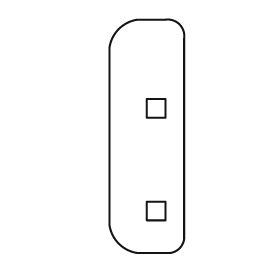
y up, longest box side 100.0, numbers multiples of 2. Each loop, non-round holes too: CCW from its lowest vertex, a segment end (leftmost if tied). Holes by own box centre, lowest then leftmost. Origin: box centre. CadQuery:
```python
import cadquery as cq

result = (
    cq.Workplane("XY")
    .moveTo(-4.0, -50.0)
    .lineTo(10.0, -50.0)
    .threePointArc((14.0, -48.0), (16.0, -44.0))
    .lineTo(16.0, 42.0)
    .threePointArc((14.0, 48.0), (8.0, 50.0))
    .lineTo(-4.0, 50.0)
    .threePointArc((-12.0, 46.0), (-16.0, 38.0))
    .lineTo(-16.0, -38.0)
    .threePointArc((-12.0, -46.0), (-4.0, -50.0))
    .close()
    .moveTo(0.0, -36.0)
    .lineTo(8.0, -36.0)
    .lineTo(8.0, -28.0)
    .lineTo(0.0, -28.0)
    .close()
    .moveTo(0.0, 8.0)
    .lineTo(8.0, 8.0)
    .lineTo(8.0, 16.0)
    .lineTo(0.0, 16.0)
    .close()
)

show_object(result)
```